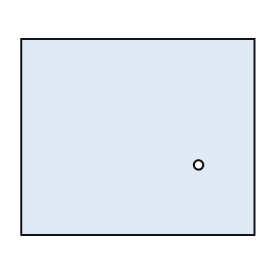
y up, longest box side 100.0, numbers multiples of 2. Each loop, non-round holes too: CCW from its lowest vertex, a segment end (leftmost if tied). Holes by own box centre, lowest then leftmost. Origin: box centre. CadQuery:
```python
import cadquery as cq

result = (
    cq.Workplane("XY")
    .moveTo(-50.0, -42.0)
    .lineTo(50.0, -42.0)
    .lineTo(50.0, 42.0)
    .lineTo(-50.0, 42.0)
    .close()
    .moveTo(26.0, -12.0)
    .circle(2.0)
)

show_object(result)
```